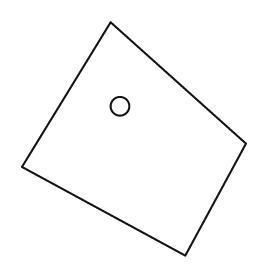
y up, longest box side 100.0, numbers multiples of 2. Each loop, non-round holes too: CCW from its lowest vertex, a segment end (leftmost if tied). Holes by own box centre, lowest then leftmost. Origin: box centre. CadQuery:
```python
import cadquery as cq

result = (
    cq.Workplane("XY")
    .moveTo(22.0, -50.0)
    .lineTo(48.0, -2.0)
    .lineTo(-10.0, 50.0)
    .lineTo(-48.0, -12.0)
    .close()
    .moveTo(-6.0, 14.0)
    .circle(4.0)
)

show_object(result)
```